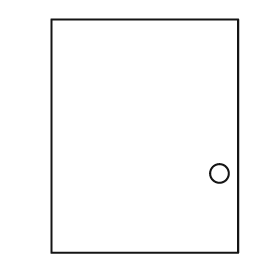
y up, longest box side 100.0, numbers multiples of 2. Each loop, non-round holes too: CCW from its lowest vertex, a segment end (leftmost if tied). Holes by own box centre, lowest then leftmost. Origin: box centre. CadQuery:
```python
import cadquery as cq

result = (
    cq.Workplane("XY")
    .moveTo(-40.0, -50.0)
    .lineTo(40.0, -50.0)
    .lineTo(40.0, 50.0)
    .lineTo(-40.0, 50.0)
    .close()
    .moveTo(32.0, -16.0)
    .circle(4.0)
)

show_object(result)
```